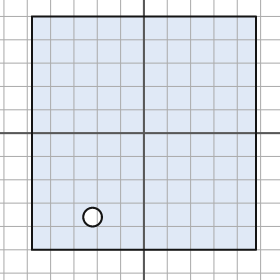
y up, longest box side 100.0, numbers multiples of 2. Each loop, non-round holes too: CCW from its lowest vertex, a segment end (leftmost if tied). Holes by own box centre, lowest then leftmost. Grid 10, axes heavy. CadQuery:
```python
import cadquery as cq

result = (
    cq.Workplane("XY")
    .moveTo(-48.0, -50.0)
    .lineTo(48.0, -50.0)
    .lineTo(48.0, 50.0)
    .lineTo(-48.0, 50.0)
    .close()
    .moveTo(-22.0, -36.0)
    .circle(4.0)
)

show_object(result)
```